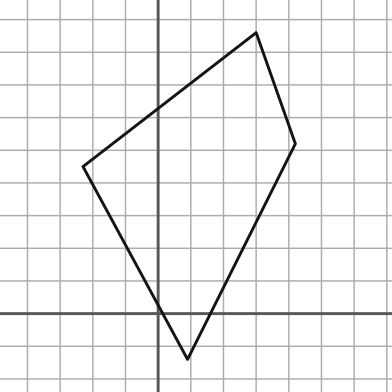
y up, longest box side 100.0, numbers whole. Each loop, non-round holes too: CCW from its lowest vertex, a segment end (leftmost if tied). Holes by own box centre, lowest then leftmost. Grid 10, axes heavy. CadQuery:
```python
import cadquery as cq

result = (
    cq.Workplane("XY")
    .moveTo(9.0, -14.0)
    .lineTo(42.0, 52.0)
    .lineTo(30.0, 86.0)
    .lineTo(-23.0, 45.0)
    .close()
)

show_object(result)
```